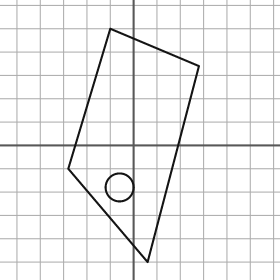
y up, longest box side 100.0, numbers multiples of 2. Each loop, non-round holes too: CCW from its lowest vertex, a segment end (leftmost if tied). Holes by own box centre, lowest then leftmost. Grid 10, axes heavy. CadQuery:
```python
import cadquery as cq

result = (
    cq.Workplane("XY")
    .moveTo(6.0, -50.0)
    .lineTo(28.0, 34.0)
    .lineTo(-10.0, 50.0)
    .lineTo(-28.0, -10.0)
    .close()
    .moveTo(-6.0, -18.0)
    .circle(6.0)
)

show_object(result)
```